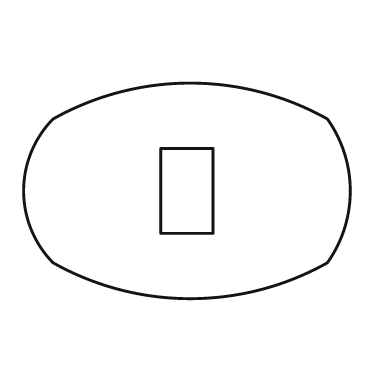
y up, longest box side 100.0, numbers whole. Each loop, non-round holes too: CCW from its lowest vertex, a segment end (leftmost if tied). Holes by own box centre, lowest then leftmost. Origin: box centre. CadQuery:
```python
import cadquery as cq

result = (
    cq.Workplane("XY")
    .moveTo(-41.0, -22.0)
    .threePointArc((1.0, -33.0), (43.0, -22.0))
    .threePointArc((50.0, 0.0), (43.0, 22.0))
    .threePointArc((1.0, 33.0), (-41.0, 22.0))
    .threePointArc((-50.0, 0.0), (-41.0, -22.0))
    .close()
    .moveTo(-8.0, -13.0)
    .lineTo(8.0, -13.0)
    .lineTo(8.0, 13.0)
    .lineTo(-8.0, 13.0)
    .close()
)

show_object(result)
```